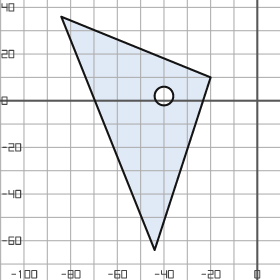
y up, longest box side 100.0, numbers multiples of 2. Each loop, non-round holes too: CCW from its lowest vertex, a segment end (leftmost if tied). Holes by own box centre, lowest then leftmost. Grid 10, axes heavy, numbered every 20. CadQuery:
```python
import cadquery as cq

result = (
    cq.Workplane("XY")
    .moveTo(-44.0, -64.0)
    .lineTo(-20.0, 10.0)
    .lineTo(-84.0, 36.0)
    .close()
    .moveTo(-40.0, 2.0)
    .circle(4.0)
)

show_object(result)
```